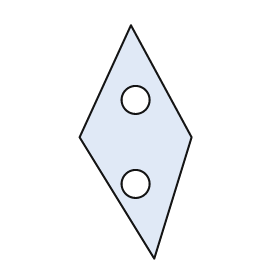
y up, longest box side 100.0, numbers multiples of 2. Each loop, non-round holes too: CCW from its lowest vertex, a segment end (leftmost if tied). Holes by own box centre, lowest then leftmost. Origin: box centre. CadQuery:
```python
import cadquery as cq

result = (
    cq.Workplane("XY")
    .moveTo(8.0, -50.0)
    .lineTo(24.0, 2.0)
    .lineTo(-2.0, 50.0)
    .lineTo(-24.0, 2.0)
    .close()
    .moveTo(0.0, -18.0)
    .circle(6.0)
    .moveTo(0.0, 18.0)
    .circle(6.0)
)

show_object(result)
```